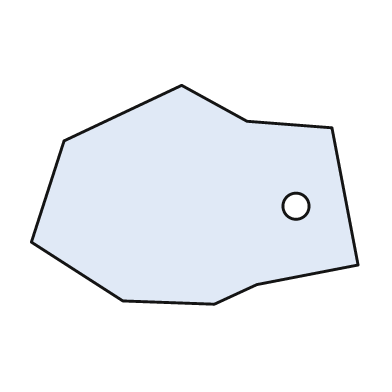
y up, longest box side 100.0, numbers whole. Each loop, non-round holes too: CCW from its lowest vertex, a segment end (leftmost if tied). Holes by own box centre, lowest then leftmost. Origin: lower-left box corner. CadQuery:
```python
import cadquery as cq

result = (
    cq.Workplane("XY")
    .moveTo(56.0, 0.0)
    .lineTo(69.0, 6.0)
    .lineTo(100.0, 12.0)
    .lineTo(92.0, 54.0)
    .lineTo(66.0, 56.0)
    .lineTo(46.0, 67.0)
    .lineTo(10.0, 50.0)
    .lineTo(0.0, 19.0)
    .lineTo(28.0, 1.0)
    .close()
    .moveTo(81.0, 30.0)
    .circle(4.0)
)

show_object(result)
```